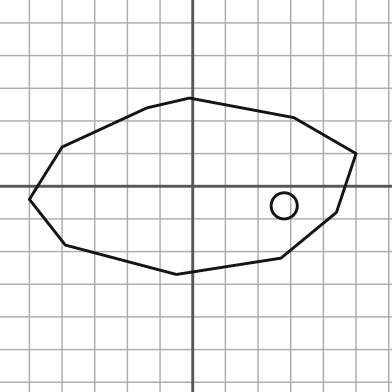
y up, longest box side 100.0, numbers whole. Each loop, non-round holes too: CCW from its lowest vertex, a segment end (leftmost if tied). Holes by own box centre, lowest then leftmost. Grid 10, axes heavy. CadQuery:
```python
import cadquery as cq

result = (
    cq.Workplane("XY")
    .moveTo(-5.0, -27.0)
    .lineTo(27.0, -22.0)
    .lineTo(44.0, -8.0)
    .lineTo(50.0, 10.0)
    .lineTo(31.0, 21.0)
    .lineTo(-1.0, 27.0)
    .lineTo(-14.0, 24.0)
    .lineTo(-40.0, 12.0)
    .lineTo(-50.0, -4.0)
    .lineTo(-39.0, -18.0)
    .close()
    .moveTo(28.0, -6.0)
    .circle(4.0)
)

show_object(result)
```